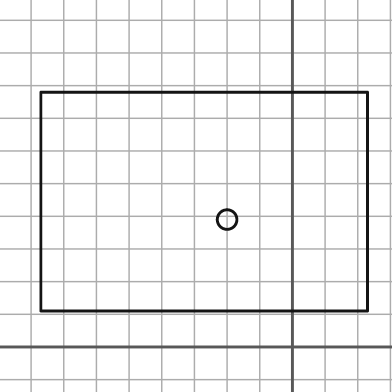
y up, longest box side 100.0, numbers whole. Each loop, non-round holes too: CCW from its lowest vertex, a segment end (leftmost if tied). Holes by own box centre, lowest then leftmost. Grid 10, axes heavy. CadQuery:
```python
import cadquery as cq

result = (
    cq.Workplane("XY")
    .moveTo(-77.0, 11.0)
    .lineTo(23.0, 11.0)
    .lineTo(23.0, 78.0)
    .lineTo(-77.0, 78.0)
    .close()
    .moveTo(-20.0, 39.0)
    .circle(3.0)
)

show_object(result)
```